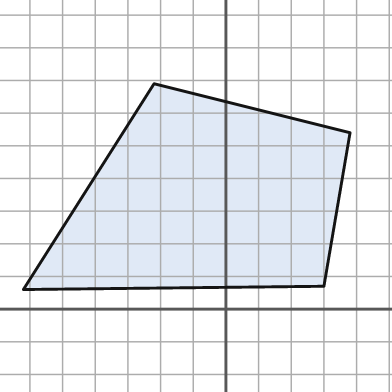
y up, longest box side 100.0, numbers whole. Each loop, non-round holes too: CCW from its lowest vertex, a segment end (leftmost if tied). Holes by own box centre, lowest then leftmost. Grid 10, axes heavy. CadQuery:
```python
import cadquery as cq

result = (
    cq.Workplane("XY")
    .moveTo(-62.0, 6.0)
    .lineTo(30.0, 7.0)
    .lineTo(38.0, 54.0)
    .lineTo(-22.0, 69.0)
    .close()
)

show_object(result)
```